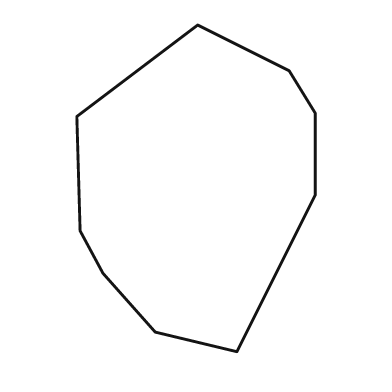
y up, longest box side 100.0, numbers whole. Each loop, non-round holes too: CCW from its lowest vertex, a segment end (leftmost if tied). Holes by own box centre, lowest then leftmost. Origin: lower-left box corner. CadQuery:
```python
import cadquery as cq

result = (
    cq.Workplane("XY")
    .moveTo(49.0, 0.0)
    .lineTo(73.0, 48.0)
    .lineTo(73.0, 73.0)
    .lineTo(65.0, 86.0)
    .lineTo(37.0, 100.0)
    .lineTo(0.0, 72.0)
    .lineTo(1.0, 37.0)
    .lineTo(8.0, 24.0)
    .lineTo(24.0, 6.0)
    .close()
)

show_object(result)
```